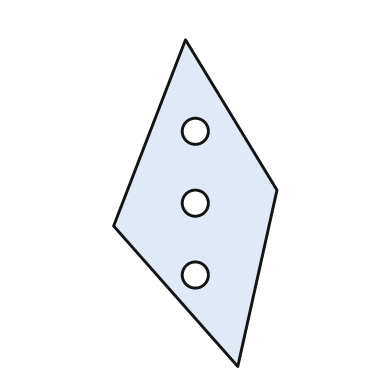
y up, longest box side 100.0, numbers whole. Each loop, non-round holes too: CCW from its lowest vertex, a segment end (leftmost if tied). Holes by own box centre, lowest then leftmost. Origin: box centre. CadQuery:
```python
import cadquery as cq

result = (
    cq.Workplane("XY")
    .moveTo(13.0, -50.0)
    .lineTo(25.0, 4.0)
    .lineTo(-3.0, 50.0)
    .lineTo(-25.0, -7.0)
    .close()
    .moveTo(0.0, -22.0)
    .circle(4.0)
    .moveTo(0.0, 0.0)
    .circle(4.0)
    .moveTo(0.0, 22.0)
    .circle(4.0)
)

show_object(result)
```